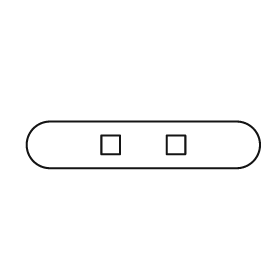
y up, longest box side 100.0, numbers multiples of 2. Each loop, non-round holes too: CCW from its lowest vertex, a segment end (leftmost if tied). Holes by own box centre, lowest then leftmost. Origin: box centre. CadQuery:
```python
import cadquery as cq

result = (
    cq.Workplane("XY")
    .moveTo(-40.0, -10.0)
    .lineTo(40.0, -10.0)
    .threePointArc((50.0, 0.0), (40.0, 10.0))
    .lineTo(-40.0, 10.0)
    .threePointArc((-50.0, 0.0), (-40.0, -10.0))
    .close()
    .moveTo(-18.0, -4.0)
    .lineTo(-10.0, -4.0)
    .lineTo(-10.0, 4.0)
    .lineTo(-18.0, 4.0)
    .close()
    .moveTo(10.0, -4.0)
    .lineTo(18.0, -4.0)
    .lineTo(18.0, 4.0)
    .lineTo(10.0, 4.0)
    .close()
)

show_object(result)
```